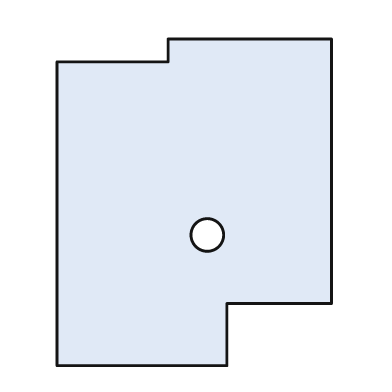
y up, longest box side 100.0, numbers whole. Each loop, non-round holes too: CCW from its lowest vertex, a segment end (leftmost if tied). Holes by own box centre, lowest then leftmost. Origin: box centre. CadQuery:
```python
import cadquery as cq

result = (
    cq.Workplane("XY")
    .moveTo(-42.0, -50.0)
    .lineTo(10.0, -50.0)
    .lineTo(10.0, -31.0)
    .lineTo(42.0, -31.0)
    .lineTo(42.0, 50.0)
    .lineTo(-8.0, 50.0)
    .lineTo(-8.0, 43.0)
    .lineTo(-42.0, 43.0)
    .close()
    .moveTo(4.0, -10.0)
    .circle(5.0)
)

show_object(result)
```